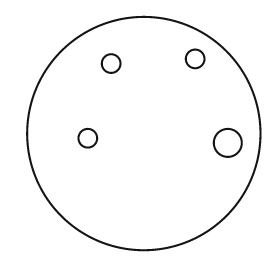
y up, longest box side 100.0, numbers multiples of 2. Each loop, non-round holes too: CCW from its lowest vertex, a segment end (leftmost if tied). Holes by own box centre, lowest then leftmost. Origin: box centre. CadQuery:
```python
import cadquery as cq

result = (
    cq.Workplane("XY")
    .moveTo(0.0, 0.0)
    .circle(50.0)
    .moveTo(36.0, -4.0)
    .circle(6.0)
    .moveTo(-24.0, -2.0)
    .circle(4.0)
    .moveTo(-14.0, 30.0)
    .circle(4.0)
    .moveTo(22.0, 32.0)
    .circle(4.0)
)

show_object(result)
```